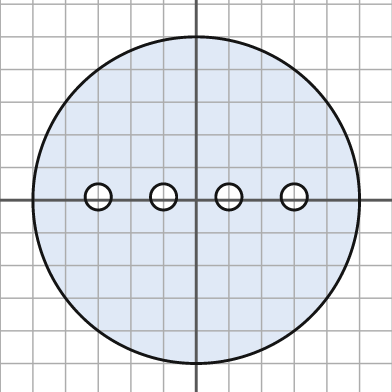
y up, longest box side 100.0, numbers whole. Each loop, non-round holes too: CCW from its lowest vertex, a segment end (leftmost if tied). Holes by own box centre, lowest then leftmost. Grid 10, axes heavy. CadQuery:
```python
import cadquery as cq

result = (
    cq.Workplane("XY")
    .moveTo(0.0, 0.0)
    .circle(50.0)
    .moveTo(-30.0, 1.0)
    .circle(4.0)
    .moveTo(-10.0, 1.0)
    .circle(4.0)
    .moveTo(10.0, 1.0)
    .circle(4.0)
    .moveTo(30.0, 1.0)
    .circle(4.0)
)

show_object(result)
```